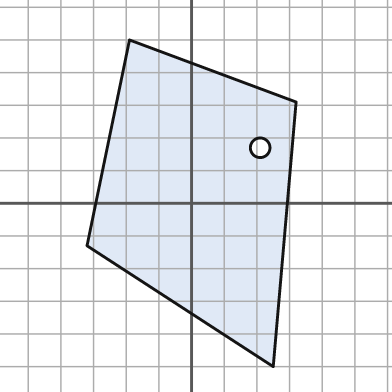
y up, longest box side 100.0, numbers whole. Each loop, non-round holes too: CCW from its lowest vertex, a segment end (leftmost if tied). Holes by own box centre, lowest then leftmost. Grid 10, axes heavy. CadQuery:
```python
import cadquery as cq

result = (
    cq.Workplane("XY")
    .moveTo(25.0, -50.0)
    .lineTo(32.0, 31.0)
    .lineTo(-19.0, 50.0)
    .lineTo(-32.0, -13.0)
    .close()
    .moveTo(21.0, 17.0)
    .circle(3.0)
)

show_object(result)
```